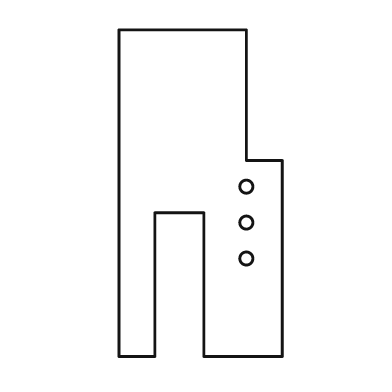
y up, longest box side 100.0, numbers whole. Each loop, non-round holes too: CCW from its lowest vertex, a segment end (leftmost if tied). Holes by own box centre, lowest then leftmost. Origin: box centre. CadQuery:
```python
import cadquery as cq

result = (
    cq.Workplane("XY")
    .moveTo(-25.0, -50.0)
    .lineTo(-14.0, -50.0)
    .lineTo(-14.0, -6.0)
    .lineTo(1.0, -6.0)
    .lineTo(1.0, -50.0)
    .lineTo(25.0, -50.0)
    .lineTo(25.0, 10.0)
    .lineTo(14.0, 10.0)
    .lineTo(14.0, 50.0)
    .lineTo(-25.0, 50.0)
    .close()
    .moveTo(14.0, -20.0)
    .circle(2.0)
    .moveTo(14.0, -9.0)
    .circle(2.0)
    .moveTo(14.0, 2.0)
    .circle(2.0)
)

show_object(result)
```